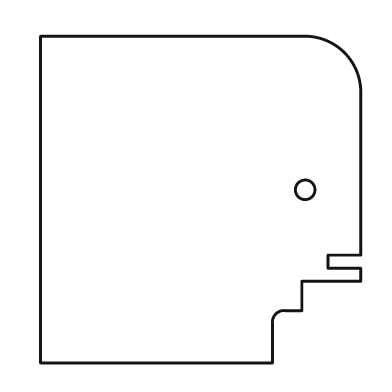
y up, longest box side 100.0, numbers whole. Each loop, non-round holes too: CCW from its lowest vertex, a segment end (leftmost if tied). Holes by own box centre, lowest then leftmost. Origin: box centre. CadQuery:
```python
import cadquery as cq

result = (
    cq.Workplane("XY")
    .moveTo(-49.0, -50.0)
    .lineTo(22.0, -50.0)
    .lineTo(22.0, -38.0)
    .threePointArc((23.0, -35.0), (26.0, -34.0))
    .lineTo(31.0, -34.0)
    .lineTo(31.0, -25.0)
    .lineTo(49.0, -25.0)
    .lineTo(49.0, -21.0)
    .lineTo(39.0, -21.0)
    .lineTo(39.0, -17.0)
    .lineTo(49.0, -17.0)
    .lineTo(49.0, 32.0)
    .threePointArc((44.0, 45.0), (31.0, 50.0))
    .lineTo(-49.0, 50.0)
    .close()
    .moveTo(32.0, 3.0)
    .circle(3.0)
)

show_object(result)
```